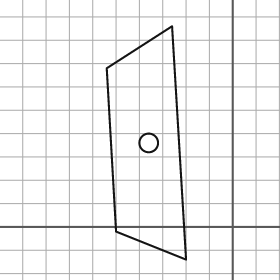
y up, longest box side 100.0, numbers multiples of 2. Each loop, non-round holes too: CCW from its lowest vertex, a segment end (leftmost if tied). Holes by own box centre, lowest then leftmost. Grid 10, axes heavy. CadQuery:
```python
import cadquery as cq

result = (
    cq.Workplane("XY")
    .moveTo(-20.0, -14.0)
    .lineTo(-26.0, 86.0)
    .lineTo(-54.0, 68.0)
    .lineTo(-50.0, -2.0)
    .close()
    .moveTo(-36.0, 36.0)
    .circle(4.0)
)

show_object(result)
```